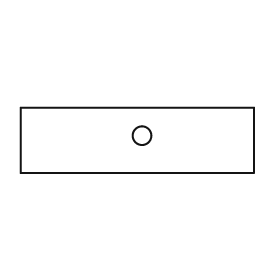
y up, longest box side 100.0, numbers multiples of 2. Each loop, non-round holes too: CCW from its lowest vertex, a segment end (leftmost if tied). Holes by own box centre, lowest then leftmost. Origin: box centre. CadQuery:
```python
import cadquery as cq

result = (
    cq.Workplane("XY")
    .moveTo(-50.0, -14.0)
    .lineTo(50.0, -14.0)
    .lineTo(50.0, 14.0)
    .lineTo(-50.0, 14.0)
    .close()
    .moveTo(2.0, 2.0)
    .circle(4.0)
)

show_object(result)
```